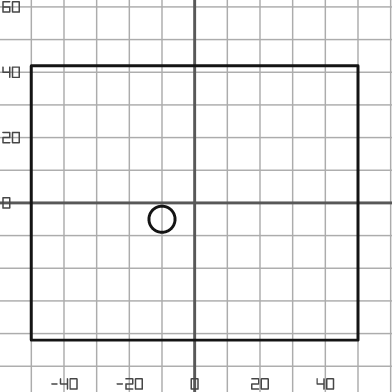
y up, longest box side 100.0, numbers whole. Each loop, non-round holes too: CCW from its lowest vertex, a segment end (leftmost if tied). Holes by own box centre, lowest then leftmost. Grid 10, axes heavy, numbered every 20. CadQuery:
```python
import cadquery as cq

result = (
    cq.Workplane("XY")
    .moveTo(-50.0, -42.0)
    .lineTo(50.0, -42.0)
    .lineTo(50.0, 42.0)
    .lineTo(-50.0, 42.0)
    .close()
    .moveTo(-10.0, -5.0)
    .circle(4.0)
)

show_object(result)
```